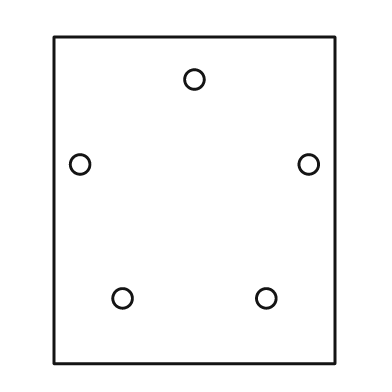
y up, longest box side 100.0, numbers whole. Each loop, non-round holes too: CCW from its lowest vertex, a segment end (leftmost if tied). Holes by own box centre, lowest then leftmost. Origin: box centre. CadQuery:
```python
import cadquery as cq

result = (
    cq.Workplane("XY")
    .moveTo(-43.0, -50.0)
    .lineTo(43.0, -50.0)
    .lineTo(43.0, 50.0)
    .lineTo(-43.0, 50.0)
    .close()
    .moveTo(-22.0, -30.0)
    .circle(3.0)
    .moveTo(22.0, -30.0)
    .circle(3.0)
    .moveTo(-35.0, 11.0)
    .circle(3.0)
    .moveTo(35.0, 11.0)
    .circle(3.0)
    .moveTo(0.0, 37.0)
    .circle(3.0)
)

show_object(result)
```